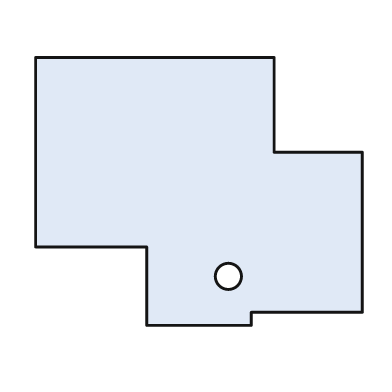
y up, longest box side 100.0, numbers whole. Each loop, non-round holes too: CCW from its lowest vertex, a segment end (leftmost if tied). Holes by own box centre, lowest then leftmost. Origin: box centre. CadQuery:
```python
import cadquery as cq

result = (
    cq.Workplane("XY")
    .moveTo(-16.0, -41.0)
    .lineTo(16.0, -41.0)
    .lineTo(16.0, -37.0)
    .lineTo(50.0, -37.0)
    .lineTo(50.0, 12.0)
    .lineTo(23.0, 12.0)
    .lineTo(23.0, 41.0)
    .lineTo(-50.0, 41.0)
    .lineTo(-50.0, -17.0)
    .lineTo(-16.0, -17.0)
    .close()
    .moveTo(9.0, -26.0)
    .circle(4.0)
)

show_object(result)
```